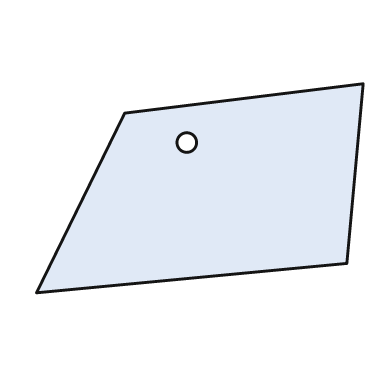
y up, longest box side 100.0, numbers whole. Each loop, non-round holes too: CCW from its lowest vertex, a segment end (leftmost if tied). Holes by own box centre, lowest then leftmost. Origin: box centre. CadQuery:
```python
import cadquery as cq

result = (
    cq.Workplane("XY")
    .moveTo(-50.0, -32.0)
    .lineTo(45.0, -23.0)
    .lineTo(50.0, 32.0)
    .lineTo(-23.0, 23.0)
    .close()
    .moveTo(-4.0, 14.0)
    .circle(3.0)
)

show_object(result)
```